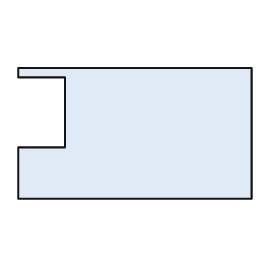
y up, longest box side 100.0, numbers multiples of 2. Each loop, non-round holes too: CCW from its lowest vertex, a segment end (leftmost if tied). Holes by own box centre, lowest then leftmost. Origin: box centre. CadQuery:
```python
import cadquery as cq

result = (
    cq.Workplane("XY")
    .moveTo(-50.0, -28.0)
    .lineTo(50.0, -28.0)
    .lineTo(50.0, 28.0)
    .lineTo(-50.0, 28.0)
    .lineTo(-50.0, 24.0)
    .lineTo(-30.0, 24.0)
    .lineTo(-30.0, -6.0)
    .lineTo(-50.0, -6.0)
    .close()
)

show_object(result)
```